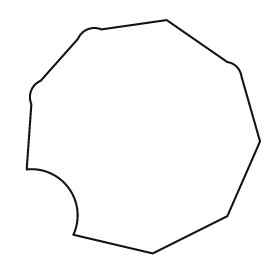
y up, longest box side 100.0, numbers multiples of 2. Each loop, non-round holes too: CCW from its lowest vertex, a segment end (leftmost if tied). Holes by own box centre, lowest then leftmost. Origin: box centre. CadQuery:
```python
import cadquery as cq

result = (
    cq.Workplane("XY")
    .moveTo(4.0, -50.0)
    .lineTo(36.0, -34.0)
    .lineTo(50.0, -2.0)
    .lineTo(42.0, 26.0)
    .threePointArc((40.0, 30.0), (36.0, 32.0))
    .lineTo(10.0, 50.0)
    .lineTo(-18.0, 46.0)
    .threePointArc((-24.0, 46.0), (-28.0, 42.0))
    .lineTo(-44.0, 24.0)
    .threePointArc((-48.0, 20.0), (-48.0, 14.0))
    .lineTo(-50.0, -14.0)
    .threePointArc((-32.0, -22.0), (-30.0, -42.0))
    .close()
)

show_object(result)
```